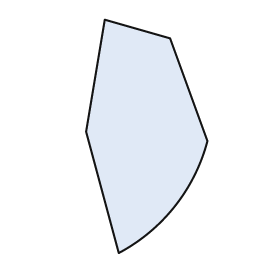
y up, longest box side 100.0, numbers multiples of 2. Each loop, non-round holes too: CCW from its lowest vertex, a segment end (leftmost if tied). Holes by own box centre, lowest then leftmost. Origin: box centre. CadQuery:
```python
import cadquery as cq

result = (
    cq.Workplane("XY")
    .moveTo(-12.0, -50.0)
    .threePointArc((12.0, -30.0), (26.0, -2.0))
    .lineTo(10.0, 42.0)
    .lineTo(-18.0, 50.0)
    .lineTo(-26.0, 2.0)
    .close()
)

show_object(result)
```